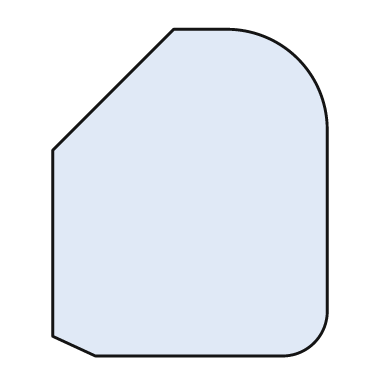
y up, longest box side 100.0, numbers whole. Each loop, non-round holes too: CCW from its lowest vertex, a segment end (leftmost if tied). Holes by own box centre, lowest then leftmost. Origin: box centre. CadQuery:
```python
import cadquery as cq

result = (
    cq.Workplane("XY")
    .moveTo(-29.0, -50.0)
    .lineTo(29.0, -50.0)
    .threePointArc((38.0, -46.0), (42.0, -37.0))
    .lineTo(42.0, 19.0)
    .threePointArc((33.0, 41.0), (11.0, 50.0))
    .lineTo(-5.0, 50.0)
    .lineTo(-42.0, 13.0)
    .lineTo(-42.0, -44.0)
    .close()
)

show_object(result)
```